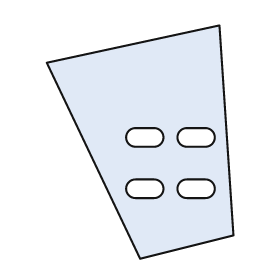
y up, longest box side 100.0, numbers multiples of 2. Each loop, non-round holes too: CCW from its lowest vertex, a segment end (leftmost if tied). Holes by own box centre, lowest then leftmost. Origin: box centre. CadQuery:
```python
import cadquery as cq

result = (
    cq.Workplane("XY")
    .moveTo(0.0, -50.0)
    .lineTo(40.0, -40.0)
    .lineTo(34.0, 50.0)
    .lineTo(-40.0, 34.0)
    .close()
    .moveTo(-2.0, -24.0)
    .lineTo(6.0, -24.0)
    .threePointArc((10.0, -20.0), (6.0, -16.0))
    .lineTo(-2.0, -16.0)
    .threePointArc((-6.0, -20.0), (-2.0, -24.0))
    .close()
    .moveTo(20.0, -24.0)
    .lineTo(28.0, -24.0)
    .threePointArc((32.0, -20.0), (28.0, -16.0))
    .lineTo(20.0, -16.0)
    .threePointArc((16.0, -20.0), (20.0, -24.0))
    .close()
    .moveTo(-2.0, -2.0)
    .lineTo(6.0, -2.0)
    .threePointArc((10.0, 2.0), (6.0, 6.0))
    .lineTo(-2.0, 6.0)
    .threePointArc((-6.0, 2.0), (-2.0, -2.0))
    .close()
    .moveTo(20.0, -2.0)
    .lineTo(28.0, -2.0)
    .threePointArc((32.0, 2.0), (28.0, 6.0))
    .lineTo(20.0, 6.0)
    .threePointArc((16.0, 2.0), (20.0, -2.0))
    .close()
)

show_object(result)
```